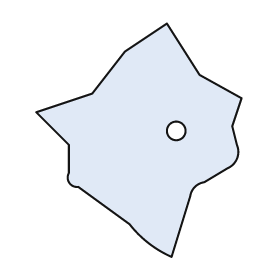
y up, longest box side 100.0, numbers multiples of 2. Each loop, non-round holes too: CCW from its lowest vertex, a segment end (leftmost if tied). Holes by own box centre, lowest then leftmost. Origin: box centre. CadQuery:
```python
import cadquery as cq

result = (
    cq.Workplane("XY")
    .moveTo(14.0, -50.0)
    .lineTo(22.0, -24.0)
    .threePointArc((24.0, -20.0), (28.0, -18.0))
    .lineTo(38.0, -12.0)
    .threePointArc((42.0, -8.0), (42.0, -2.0))
    .lineTo(40.0, 6.0)
    .lineTo(44.0, 18.0)
    .lineTo(26.0, 28.0)
    .lineTo(12.0, 50.0)
    .lineTo(-6.0, 38.0)
    .lineTo(-20.0, 20.0)
    .lineTo(-44.0, 12.0)
    .lineTo(-30.0, -2.0)
    .lineTo(-30.0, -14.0)
    .threePointArc((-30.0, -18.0), (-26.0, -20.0))
    .lineTo(-4.0, -36.0)
    .threePointArc((4.0, -44.0), (14.0, -50.0))
    .close()
    .moveTo(16.0, 4.0)
    .circle(4.0)
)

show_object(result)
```